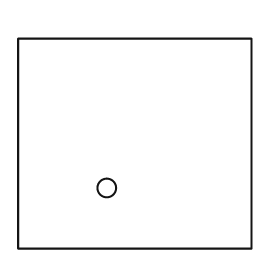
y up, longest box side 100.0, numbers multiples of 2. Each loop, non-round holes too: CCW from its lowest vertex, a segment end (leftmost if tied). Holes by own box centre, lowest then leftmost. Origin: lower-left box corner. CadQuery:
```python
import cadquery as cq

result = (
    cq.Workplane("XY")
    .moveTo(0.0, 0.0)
    .lineTo(100.0, 0.0)
    .lineTo(100.0, 90.0)
    .lineTo(0.0, 90.0)
    .close()
    .moveTo(38.0, 26.0)
    .circle(4.0)
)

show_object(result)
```